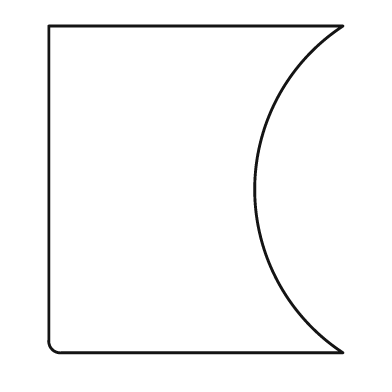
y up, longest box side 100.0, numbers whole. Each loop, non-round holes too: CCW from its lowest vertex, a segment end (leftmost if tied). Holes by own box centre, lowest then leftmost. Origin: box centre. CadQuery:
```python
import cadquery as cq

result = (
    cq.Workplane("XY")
    .moveTo(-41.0, -50.0)
    .lineTo(45.0, -50.0)
    .threePointArc((18.0, 0.0), (45.0, 50.0))
    .lineTo(-45.0, 50.0)
    .lineTo(-45.0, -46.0)
    .threePointArc((-44.0, -49.0), (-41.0, -50.0))
    .close()
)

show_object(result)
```